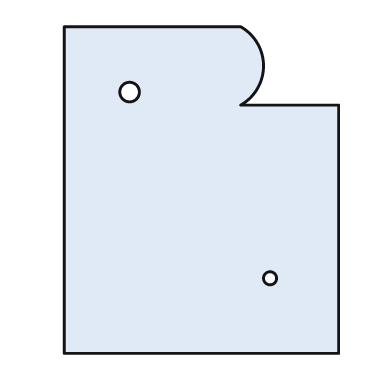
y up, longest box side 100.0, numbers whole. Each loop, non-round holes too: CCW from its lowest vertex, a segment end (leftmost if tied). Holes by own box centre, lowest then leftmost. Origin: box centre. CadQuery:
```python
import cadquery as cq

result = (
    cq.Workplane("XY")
    .moveTo(-42.0, -50.0)
    .lineTo(42.0, -50.0)
    .lineTo(42.0, 26.0)
    .lineTo(12.0, 26.0)
    .threePointArc((19.0, 38.0), (12.0, 50.0))
    .lineTo(-42.0, 50.0)
    .close()
    .moveTo(21.0, -27.0)
    .circle(2.0)
    .moveTo(-22.0, 30.0)
    .circle(3.0)
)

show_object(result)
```